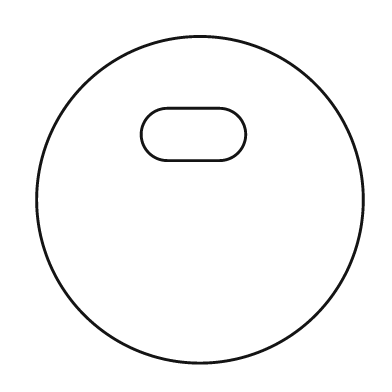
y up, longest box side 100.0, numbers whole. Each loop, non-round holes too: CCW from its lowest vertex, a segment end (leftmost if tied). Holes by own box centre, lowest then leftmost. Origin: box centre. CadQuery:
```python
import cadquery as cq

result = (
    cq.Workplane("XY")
    .moveTo(0.0, 0.0)
    .circle(50.0)
    .moveTo(-10.0, 12.0)
    .lineTo(6.0, 12.0)
    .threePointArc((14.0, 20.0), (6.0, 28.0))
    .lineTo(-10.0, 28.0)
    .threePointArc((-18.0, 20.0), (-10.0, 12.0))
    .close()
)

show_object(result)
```